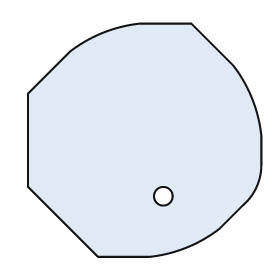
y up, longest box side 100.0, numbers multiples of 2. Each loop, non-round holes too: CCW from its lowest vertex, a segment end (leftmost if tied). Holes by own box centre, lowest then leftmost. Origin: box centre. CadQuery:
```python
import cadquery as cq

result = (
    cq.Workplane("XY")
    .moveTo(-20.0, -50.0)
    .lineTo(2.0, -50.0)
    .threePointArc((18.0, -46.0), (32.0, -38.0))
    .lineTo(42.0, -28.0)
    .threePointArc((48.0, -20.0), (50.0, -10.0))
    .lineTo(50.0, 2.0)
    .threePointArc((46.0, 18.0), (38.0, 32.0))
    .lineTo(20.0, 50.0)
    .lineTo(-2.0, 50.0)
    .threePointArc((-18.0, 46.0), (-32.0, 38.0))
    .lineTo(-50.0, 20.0)
    .lineTo(-50.0, -20.0)
    .close()
    .moveTo(8.0, -24.0)
    .circle(4.0)
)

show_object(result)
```